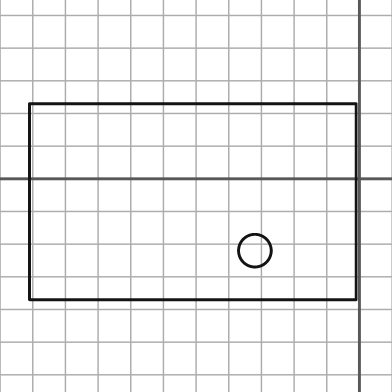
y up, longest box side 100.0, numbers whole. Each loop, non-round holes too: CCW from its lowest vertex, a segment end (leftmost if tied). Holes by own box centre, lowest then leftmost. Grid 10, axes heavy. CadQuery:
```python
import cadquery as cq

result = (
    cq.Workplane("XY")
    .moveTo(-101.0, -37.0)
    .lineTo(-1.0, -37.0)
    .lineTo(-1.0, 23.0)
    .lineTo(-101.0, 23.0)
    .close()
    .moveTo(-32.0, -22.0)
    .circle(5.0)
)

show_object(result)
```